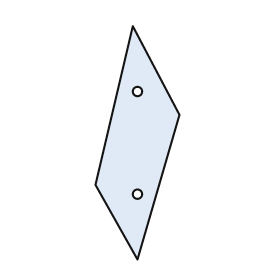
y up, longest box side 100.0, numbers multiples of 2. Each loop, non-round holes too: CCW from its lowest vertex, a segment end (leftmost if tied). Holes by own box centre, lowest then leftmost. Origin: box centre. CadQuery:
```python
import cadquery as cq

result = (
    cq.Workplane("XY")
    .moveTo(0.0, -50.0)
    .lineTo(18.0, 12.0)
    .lineTo(-2.0, 50.0)
    .lineTo(-18.0, -18.0)
    .close()
    .moveTo(0.0, -22.0)
    .circle(2.0)
    .moveTo(0.0, 22.0)
    .circle(2.0)
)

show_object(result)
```